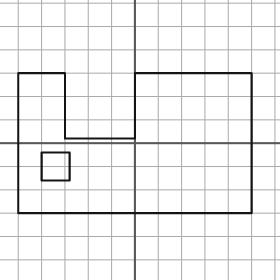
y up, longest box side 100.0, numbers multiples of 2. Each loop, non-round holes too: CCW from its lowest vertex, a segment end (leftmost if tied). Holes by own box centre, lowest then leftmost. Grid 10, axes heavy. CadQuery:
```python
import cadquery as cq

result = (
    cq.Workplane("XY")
    .moveTo(-50.0, -30.0)
    .lineTo(50.0, -30.0)
    .lineTo(50.0, 30.0)
    .lineTo(0.0, 30.0)
    .lineTo(0.0, 2.0)
    .lineTo(-30.0, 2.0)
    .lineTo(-30.0, 30.0)
    .lineTo(-50.0, 30.0)
    .close()
    .moveTo(-40.0, -16.0)
    .lineTo(-28.0, -16.0)
    .lineTo(-28.0, -4.0)
    .lineTo(-40.0, -4.0)
    .close()
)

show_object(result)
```